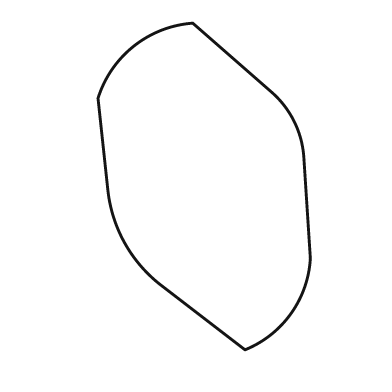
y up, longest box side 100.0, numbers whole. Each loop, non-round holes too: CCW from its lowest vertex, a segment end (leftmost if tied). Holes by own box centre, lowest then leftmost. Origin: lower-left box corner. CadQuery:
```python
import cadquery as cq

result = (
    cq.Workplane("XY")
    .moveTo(45.0, 0.0)
    .threePointArc((59.0, 11.0), (65.0, 28.0))
    .lineTo(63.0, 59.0)
    .threePointArc((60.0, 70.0), (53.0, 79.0))
    .lineTo(29.0, 100.0)
    .threePointArc((11.0, 93.0), (0.0, 77.0))
    .lineTo(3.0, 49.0)
    .threePointArc((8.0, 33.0), (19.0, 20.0))
    .close()
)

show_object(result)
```